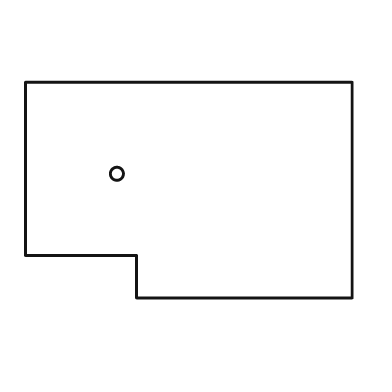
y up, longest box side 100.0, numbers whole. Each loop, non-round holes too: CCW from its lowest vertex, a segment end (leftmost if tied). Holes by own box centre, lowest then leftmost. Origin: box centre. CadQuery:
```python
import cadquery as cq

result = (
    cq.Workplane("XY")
    .moveTo(-16.0, -33.0)
    .lineTo(50.0, -33.0)
    .lineTo(50.0, 33.0)
    .lineTo(-50.0, 33.0)
    .lineTo(-50.0, -20.0)
    .lineTo(-16.0, -20.0)
    .close()
    .moveTo(-22.0, 5.0)
    .circle(2.0)
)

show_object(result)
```